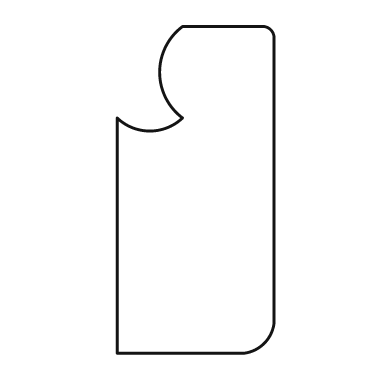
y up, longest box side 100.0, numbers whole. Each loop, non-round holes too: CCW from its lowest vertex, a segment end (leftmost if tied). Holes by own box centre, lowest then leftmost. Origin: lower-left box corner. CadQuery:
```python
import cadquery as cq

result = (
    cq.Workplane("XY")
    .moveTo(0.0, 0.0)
    .lineTo(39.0, 0.0)
    .threePointArc((45.0, 3.0), (48.0, 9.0))
    .lineTo(48.0, 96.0)
    .threePointArc((47.0, 99.0), (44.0, 100.0))
    .lineTo(20.0, 100.0)
    .threePointArc((13.0, 86.0), (20.0, 72.0))
    .threePointArc((10.0, 68.0), (0.0, 72.0))
    .close()
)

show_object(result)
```